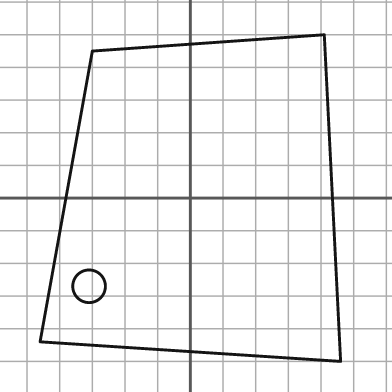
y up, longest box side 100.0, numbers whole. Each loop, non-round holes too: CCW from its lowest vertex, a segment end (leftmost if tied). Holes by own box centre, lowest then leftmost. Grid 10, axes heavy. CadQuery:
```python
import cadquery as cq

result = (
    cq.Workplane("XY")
    .moveTo(46.0, -50.0)
    .lineTo(41.0, 50.0)
    .lineTo(-30.0, 45.0)
    .lineTo(-46.0, -44.0)
    .close()
    .moveTo(-31.0, -27.0)
    .circle(5.0)
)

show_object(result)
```